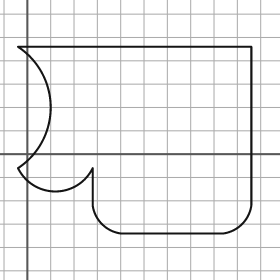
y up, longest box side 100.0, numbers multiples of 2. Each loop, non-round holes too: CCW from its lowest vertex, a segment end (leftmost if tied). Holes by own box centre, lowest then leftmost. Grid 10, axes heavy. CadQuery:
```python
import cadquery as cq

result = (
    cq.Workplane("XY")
    .moveTo(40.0, -34.0)
    .lineTo(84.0, -34.0)
    .threePointArc((92.0, -30.0), (96.0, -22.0))
    .lineTo(96.0, 46.0)
    .lineTo(-4.0, 46.0)
    .threePointArc((10.0, 20.0), (-4.0, -6.0))
    .threePointArc((12.0, -16.0), (28.0, -6.0))
    .lineTo(28.0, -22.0)
    .threePointArc((32.0, -30.0), (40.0, -34.0))
    .close()
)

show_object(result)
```